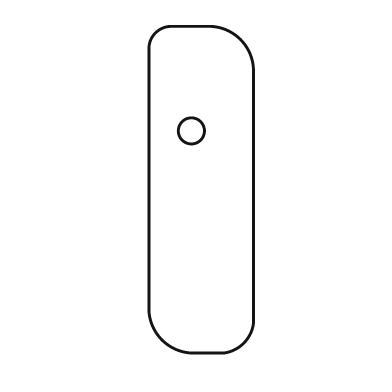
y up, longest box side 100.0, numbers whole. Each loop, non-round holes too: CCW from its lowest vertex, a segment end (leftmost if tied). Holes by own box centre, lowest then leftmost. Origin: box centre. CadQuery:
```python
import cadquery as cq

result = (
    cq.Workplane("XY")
    .moveTo(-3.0, -50.0)
    .lineTo(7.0, -50.0)
    .threePointArc((13.0, -47.0), (16.0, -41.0))
    .lineTo(16.0, 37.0)
    .threePointArc((12.0, 46.0), (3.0, 50.0))
    .lineTo(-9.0, 50.0)
    .threePointArc((-14.0, 48.0), (-16.0, 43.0))
    .lineTo(-16.0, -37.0)
    .threePointArc((-12.0, -46.0), (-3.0, -50.0))
    .close()
    .moveTo(-3.0, 18.0)
    .circle(4.0)
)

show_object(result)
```